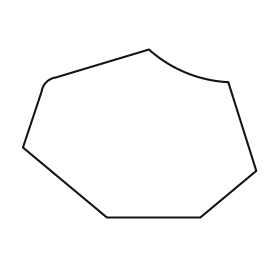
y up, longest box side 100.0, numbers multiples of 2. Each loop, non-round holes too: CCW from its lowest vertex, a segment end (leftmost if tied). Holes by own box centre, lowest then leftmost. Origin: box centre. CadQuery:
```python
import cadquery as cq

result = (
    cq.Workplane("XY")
    .moveTo(-14.0, -36.0)
    .lineTo(26.0, -36.0)
    .lineTo(50.0, -16.0)
    .lineTo(38.0, 22.0)
    .threePointArc((20.0, 26.0), (4.0, 36.0))
    .lineTo(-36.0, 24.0)
    .threePointArc((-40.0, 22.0), (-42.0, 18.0))
    .lineTo(-50.0, -6.0)
    .close()
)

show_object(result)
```